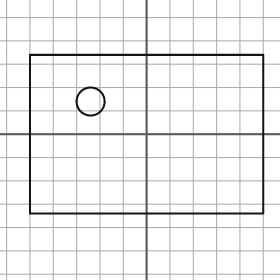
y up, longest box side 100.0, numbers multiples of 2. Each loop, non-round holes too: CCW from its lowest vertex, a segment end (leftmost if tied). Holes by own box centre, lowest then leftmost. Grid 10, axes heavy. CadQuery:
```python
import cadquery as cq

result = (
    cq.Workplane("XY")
    .moveTo(-50.0, -34.0)
    .lineTo(50.0, -34.0)
    .lineTo(50.0, 34.0)
    .lineTo(-50.0, 34.0)
    .close()
    .moveTo(-24.0, 14.0)
    .circle(6.0)
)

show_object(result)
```